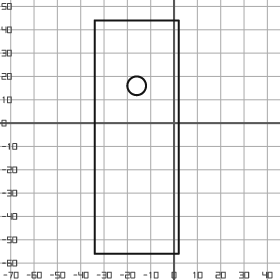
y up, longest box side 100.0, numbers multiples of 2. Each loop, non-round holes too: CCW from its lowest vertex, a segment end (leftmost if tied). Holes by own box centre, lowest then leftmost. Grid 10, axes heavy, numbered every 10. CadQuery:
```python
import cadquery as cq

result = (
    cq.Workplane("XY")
    .moveTo(-34.0, -56.0)
    .lineTo(2.0, -56.0)
    .lineTo(2.0, 44.0)
    .lineTo(-34.0, 44.0)
    .close()
    .moveTo(-16.0, 16.0)
    .circle(4.0)
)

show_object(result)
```